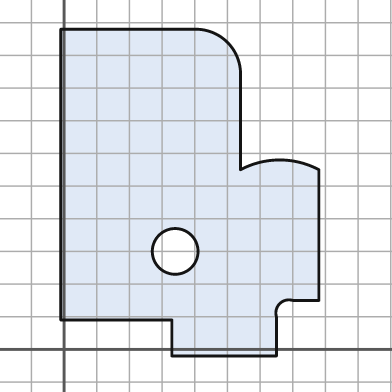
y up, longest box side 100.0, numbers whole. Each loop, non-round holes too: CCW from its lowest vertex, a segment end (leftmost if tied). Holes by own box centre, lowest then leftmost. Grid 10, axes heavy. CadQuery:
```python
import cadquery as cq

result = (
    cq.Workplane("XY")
    .moveTo(33.0, -2.0)
    .lineTo(65.0, -2.0)
    .lineTo(65.0, 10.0)
    .threePointArc((66.0, 14.0), (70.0, 15.0))
    .lineTo(78.0, 15.0)
    .lineTo(78.0, 55.0)
    .threePointArc((66.0, 58.0), (54.0, 55.0))
    .lineTo(54.0, 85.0)
    .threePointArc((50.0, 94.0), (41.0, 98.0))
    .lineTo(-1.0, 98.0)
    .lineTo(-1.0, 9.0)
    .lineTo(33.0, 9.0)
    .close()
    .moveTo(34.0, 30.0)
    .circle(7.0)
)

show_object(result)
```